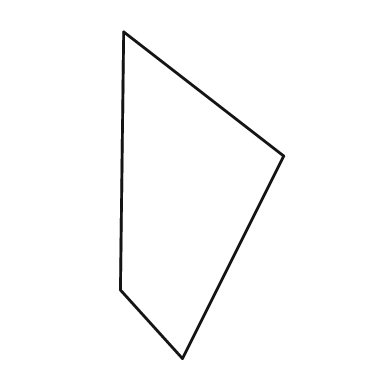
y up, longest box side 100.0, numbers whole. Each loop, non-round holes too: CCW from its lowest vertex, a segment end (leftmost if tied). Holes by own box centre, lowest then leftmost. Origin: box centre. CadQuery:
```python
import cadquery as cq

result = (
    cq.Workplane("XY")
    .moveTo(-6.0, -50.0)
    .lineTo(25.0, 12.0)
    .lineTo(-24.0, 50.0)
    .lineTo(-25.0, -29.0)
    .close()
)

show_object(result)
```